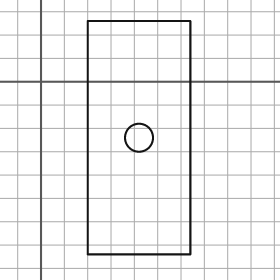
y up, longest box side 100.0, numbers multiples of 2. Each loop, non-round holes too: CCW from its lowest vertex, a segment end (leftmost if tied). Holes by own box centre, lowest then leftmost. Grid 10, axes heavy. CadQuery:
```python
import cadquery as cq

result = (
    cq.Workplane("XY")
    .moveTo(20.0, -74.0)
    .lineTo(64.0, -74.0)
    .lineTo(64.0, 26.0)
    .lineTo(20.0, 26.0)
    .close()
    .moveTo(42.0, -24.0)
    .circle(6.0)
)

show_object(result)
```